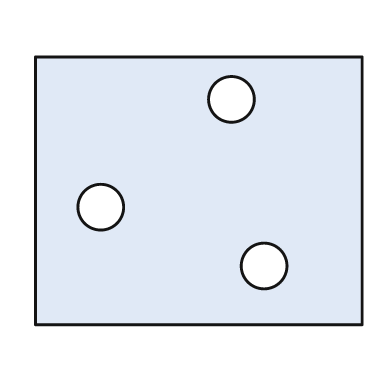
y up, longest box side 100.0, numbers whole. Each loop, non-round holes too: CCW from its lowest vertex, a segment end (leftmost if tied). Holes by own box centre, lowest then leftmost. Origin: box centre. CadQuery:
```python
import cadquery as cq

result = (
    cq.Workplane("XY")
    .moveTo(-50.0, -41.0)
    .lineTo(50.0, -41.0)
    .lineTo(50.0, 41.0)
    .lineTo(-50.0, 41.0)
    .close()
    .moveTo(20.0, -23.0)
    .circle(7.0)
    .moveTo(-30.0, -5.0)
    .circle(7.0)
    .moveTo(10.0, 28.0)
    .circle(7.0)
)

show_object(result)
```